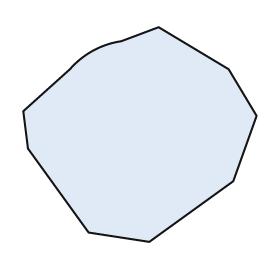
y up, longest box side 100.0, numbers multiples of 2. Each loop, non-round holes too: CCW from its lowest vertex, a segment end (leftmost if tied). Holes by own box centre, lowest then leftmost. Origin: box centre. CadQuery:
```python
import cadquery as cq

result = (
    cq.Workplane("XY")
    .moveTo(4.0, -46.0)
    .lineTo(40.0, -20.0)
    .lineTo(50.0, 8.0)
    .lineTo(38.0, 28.0)
    .lineTo(8.0, 46.0)
    .lineTo(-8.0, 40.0)
    .threePointArc((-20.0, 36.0), (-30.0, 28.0))
    .lineTo(-50.0, 10.0)
    .lineTo(-48.0, -6.0)
    .lineTo(-22.0, -42.0)
    .close()
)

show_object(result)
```